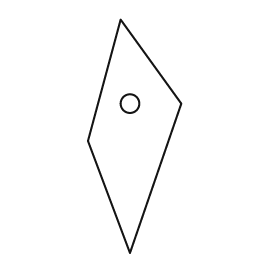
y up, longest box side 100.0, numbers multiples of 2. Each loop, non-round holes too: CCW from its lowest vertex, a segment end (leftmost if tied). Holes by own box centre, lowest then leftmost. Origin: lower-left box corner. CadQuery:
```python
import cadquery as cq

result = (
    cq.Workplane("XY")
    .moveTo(18.0, 0.0)
    .lineTo(40.0, 64.0)
    .lineTo(14.0, 100.0)
    .lineTo(0.0, 48.0)
    .close()
    .moveTo(18.0, 64.0)
    .circle(4.0)
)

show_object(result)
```